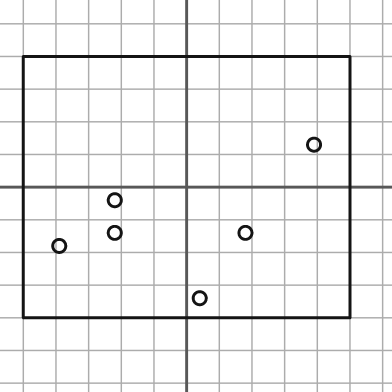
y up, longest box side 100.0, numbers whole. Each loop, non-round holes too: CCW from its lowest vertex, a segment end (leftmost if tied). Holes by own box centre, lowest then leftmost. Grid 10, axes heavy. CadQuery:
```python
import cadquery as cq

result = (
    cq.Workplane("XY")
    .moveTo(-50.0, -40.0)
    .lineTo(50.0, -40.0)
    .lineTo(50.0, 40.0)
    .lineTo(-50.0, 40.0)
    .close()
    .moveTo(4.0, -34.0)
    .circle(2.0)
    .moveTo(-39.0, -18.0)
    .circle(2.0)
    .moveTo(-22.0, -14.0)
    .circle(2.0)
    .moveTo(18.0, -14.0)
    .circle(2.0)
    .moveTo(-22.0, -4.0)
    .circle(2.0)
    .moveTo(39.0, 13.0)
    .circle(2.0)
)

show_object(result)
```